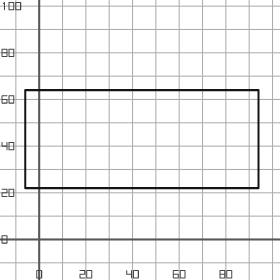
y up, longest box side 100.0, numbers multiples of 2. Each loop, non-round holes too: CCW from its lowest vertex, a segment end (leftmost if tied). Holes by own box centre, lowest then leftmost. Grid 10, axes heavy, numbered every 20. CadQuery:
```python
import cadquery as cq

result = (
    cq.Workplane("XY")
    .moveTo(-6.0, 22.0)
    .lineTo(94.0, 22.0)
    .lineTo(94.0, 64.0)
    .lineTo(-6.0, 64.0)
    .close()
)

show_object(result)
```